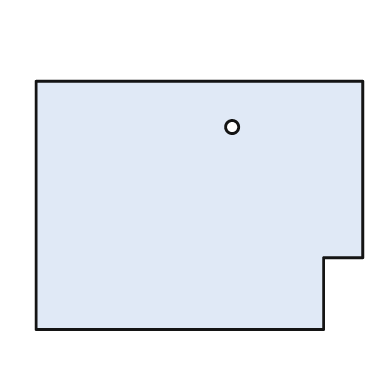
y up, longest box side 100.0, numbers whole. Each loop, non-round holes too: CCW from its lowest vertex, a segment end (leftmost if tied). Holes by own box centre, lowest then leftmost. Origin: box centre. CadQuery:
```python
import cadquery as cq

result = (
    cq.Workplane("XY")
    .moveTo(-50.0, -38.0)
    .lineTo(38.0, -38.0)
    .lineTo(38.0, -16.0)
    .lineTo(50.0, -16.0)
    .lineTo(50.0, 38.0)
    .lineTo(-50.0, 38.0)
    .close()
    .moveTo(10.0, 24.0)
    .circle(2.0)
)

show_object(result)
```